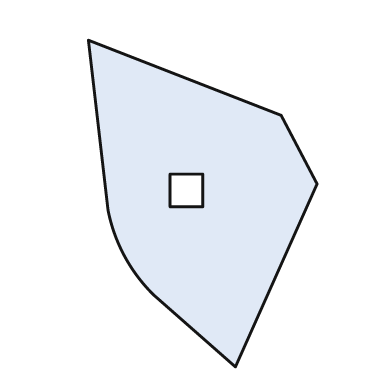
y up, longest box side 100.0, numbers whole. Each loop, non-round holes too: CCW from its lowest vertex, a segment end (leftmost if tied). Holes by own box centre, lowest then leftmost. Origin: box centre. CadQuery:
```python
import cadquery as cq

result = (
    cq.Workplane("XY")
    .moveTo(10.0, -50.0)
    .lineTo(35.0, 6.0)
    .lineTo(24.0, 27.0)
    .lineTo(-35.0, 50.0)
    .lineTo(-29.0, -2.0)
    .threePointArc((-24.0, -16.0), (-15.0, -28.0))
    .close()
    .moveTo(-10.0, -1.0)
    .lineTo(0.0, -1.0)
    .lineTo(0.0, 9.0)
    .lineTo(-10.0, 9.0)
    .close()
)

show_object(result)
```